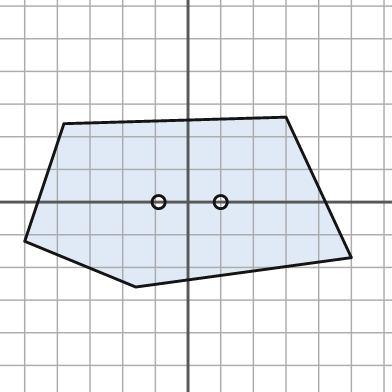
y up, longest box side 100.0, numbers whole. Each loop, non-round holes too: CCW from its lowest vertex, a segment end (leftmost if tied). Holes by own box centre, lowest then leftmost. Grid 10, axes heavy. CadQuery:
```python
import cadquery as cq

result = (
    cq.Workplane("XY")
    .moveTo(-16.0, -26.0)
    .lineTo(50.0, -17.0)
    .lineTo(30.0, 26.0)
    .lineTo(-38.0, 24.0)
    .lineTo(-50.0, -12.0)
    .close()
    .moveTo(-9.0, 0.0)
    .circle(2.0)
    .moveTo(10.0, 0.0)
    .circle(2.0)
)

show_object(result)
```